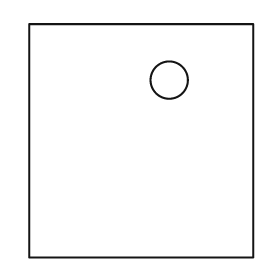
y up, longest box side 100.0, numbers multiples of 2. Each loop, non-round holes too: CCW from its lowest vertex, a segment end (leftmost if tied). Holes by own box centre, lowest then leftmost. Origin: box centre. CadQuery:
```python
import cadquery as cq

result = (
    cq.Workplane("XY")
    .moveTo(-48.0, -50.0)
    .lineTo(48.0, -50.0)
    .lineTo(48.0, 50.0)
    .lineTo(-48.0, 50.0)
    .close()
    .moveTo(12.0, 26.0)
    .circle(8.0)
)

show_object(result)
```